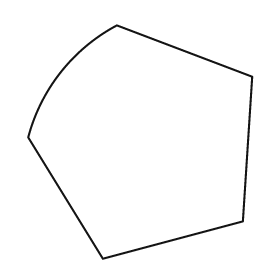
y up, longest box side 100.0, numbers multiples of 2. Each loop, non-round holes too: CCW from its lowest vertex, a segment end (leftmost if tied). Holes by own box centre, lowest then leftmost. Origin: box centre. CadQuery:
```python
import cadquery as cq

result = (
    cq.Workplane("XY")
    .moveTo(-16.0, -50.0)
    .lineTo(44.0, -34.0)
    .lineTo(48.0, 28.0)
    .lineTo(-10.0, 50.0)
    .threePointArc((-34.0, 30.0), (-48.0, 2.0))
    .close()
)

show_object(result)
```